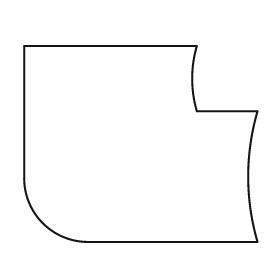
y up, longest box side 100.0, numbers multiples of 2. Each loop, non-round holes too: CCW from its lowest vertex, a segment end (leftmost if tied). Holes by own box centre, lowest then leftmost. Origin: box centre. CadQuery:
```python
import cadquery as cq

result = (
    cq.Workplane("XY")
    .moveTo(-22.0, -42.0)
    .lineTo(50.0, -42.0)
    .threePointArc((46.0, -14.0), (50.0, 14.0))
    .lineTo(24.0, 14.0)
    .threePointArc((22.0, 28.0), (24.0, 42.0))
    .lineTo(-50.0, 42.0)
    .lineTo(-50.0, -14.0)
    .threePointArc((-42.0, -34.0), (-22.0, -42.0))
    .close()
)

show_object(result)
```